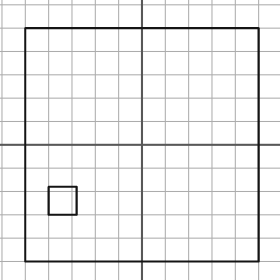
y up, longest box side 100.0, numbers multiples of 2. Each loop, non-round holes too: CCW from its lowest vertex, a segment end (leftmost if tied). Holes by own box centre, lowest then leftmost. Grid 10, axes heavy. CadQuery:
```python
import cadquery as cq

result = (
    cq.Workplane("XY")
    .moveTo(-50.0, -50.0)
    .lineTo(50.0, -50.0)
    .lineTo(50.0, 50.0)
    .lineTo(-50.0, 50.0)
    .close()
    .moveTo(-40.0, -30.0)
    .lineTo(-28.0, -30.0)
    .lineTo(-28.0, -18.0)
    .lineTo(-40.0, -18.0)
    .close()
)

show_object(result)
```